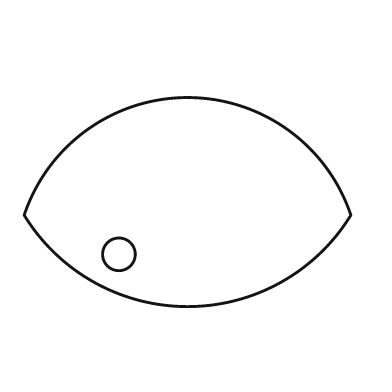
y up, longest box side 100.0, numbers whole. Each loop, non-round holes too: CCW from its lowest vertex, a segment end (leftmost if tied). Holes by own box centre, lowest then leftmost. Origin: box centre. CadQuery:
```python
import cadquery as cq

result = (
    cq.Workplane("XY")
    .moveTo(-50.0, -4.0)
    .threePointArc((0.0, -32.0), (50.0, -4.0))
    .threePointArc((0.0, 32.0), (-50.0, -4.0))
    .close()
    .moveTo(-21.0, -16.0)
    .circle(5.0)
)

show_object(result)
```